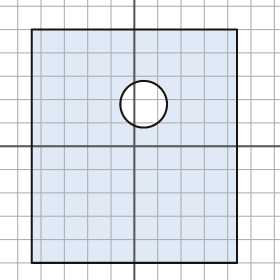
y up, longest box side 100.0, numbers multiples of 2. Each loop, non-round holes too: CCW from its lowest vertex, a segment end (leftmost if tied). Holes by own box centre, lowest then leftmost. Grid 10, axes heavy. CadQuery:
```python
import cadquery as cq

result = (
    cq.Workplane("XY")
    .moveTo(-44.0, -50.0)
    .lineTo(44.0, -50.0)
    .lineTo(44.0, 50.0)
    .lineTo(-44.0, 50.0)
    .close()
    .moveTo(4.0, 18.0)
    .circle(10.0)
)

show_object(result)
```